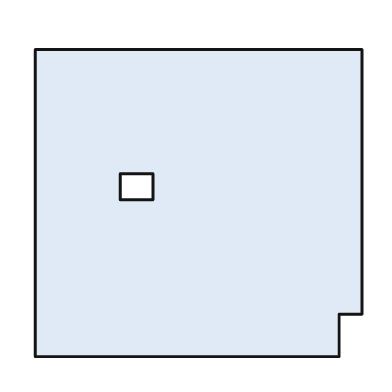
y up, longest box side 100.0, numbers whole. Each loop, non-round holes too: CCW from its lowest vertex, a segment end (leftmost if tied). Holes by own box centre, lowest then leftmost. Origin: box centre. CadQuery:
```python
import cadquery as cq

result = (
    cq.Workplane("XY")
    .moveTo(-50.0, -47.0)
    .lineTo(43.0, -47.0)
    .lineTo(43.0, -34.0)
    .lineTo(50.0, -34.0)
    .lineTo(50.0, 47.0)
    .lineTo(-50.0, 47.0)
    .close()
    .moveTo(-24.0, 1.0)
    .lineTo(-14.0, 1.0)
    .lineTo(-14.0, 9.0)
    .lineTo(-24.0, 9.0)
    .close()
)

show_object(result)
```